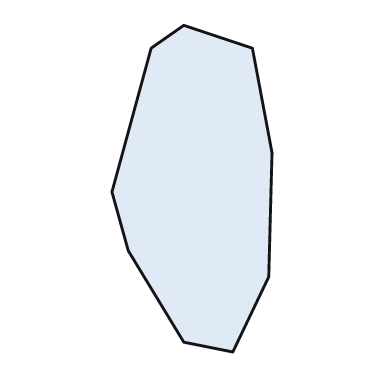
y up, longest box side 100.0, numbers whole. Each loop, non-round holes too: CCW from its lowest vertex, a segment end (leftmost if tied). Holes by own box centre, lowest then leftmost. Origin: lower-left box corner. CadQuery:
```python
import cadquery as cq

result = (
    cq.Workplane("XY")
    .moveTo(37.0, 0.0)
    .lineTo(48.0, 23.0)
    .lineTo(49.0, 61.0)
    .lineTo(43.0, 93.0)
    .lineTo(22.0, 100.0)
    .lineTo(12.0, 93.0)
    .lineTo(0.0, 49.0)
    .lineTo(5.0, 31.0)
    .lineTo(22.0, 3.0)
    .close()
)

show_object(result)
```